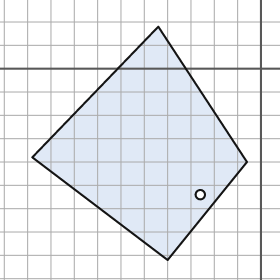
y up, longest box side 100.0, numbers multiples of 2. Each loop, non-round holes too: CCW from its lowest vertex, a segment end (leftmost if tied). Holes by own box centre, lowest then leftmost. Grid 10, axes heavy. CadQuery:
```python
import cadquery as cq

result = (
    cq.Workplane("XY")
    .moveTo(-40.0, -82.0)
    .lineTo(-6.0, -40.0)
    .lineTo(-44.0, 18.0)
    .lineTo(-98.0, -38.0)
    .close()
    .moveTo(-26.0, -54.0)
    .circle(2.0)
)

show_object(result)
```